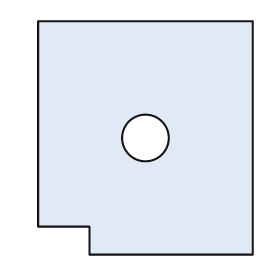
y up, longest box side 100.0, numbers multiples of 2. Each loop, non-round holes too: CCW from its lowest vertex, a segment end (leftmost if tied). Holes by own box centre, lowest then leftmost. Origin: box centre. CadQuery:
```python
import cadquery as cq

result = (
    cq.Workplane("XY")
    .moveTo(-24.0, -50.0)
    .lineTo(46.0, -50.0)
    .lineTo(46.0, 50.0)
    .lineTo(-46.0, 50.0)
    .lineTo(-46.0, -38.0)
    .lineTo(-24.0, -38.0)
    .close()
    .moveTo(0.0, 0.0)
    .circle(10.0)
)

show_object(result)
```